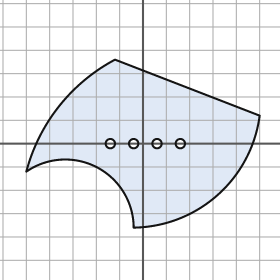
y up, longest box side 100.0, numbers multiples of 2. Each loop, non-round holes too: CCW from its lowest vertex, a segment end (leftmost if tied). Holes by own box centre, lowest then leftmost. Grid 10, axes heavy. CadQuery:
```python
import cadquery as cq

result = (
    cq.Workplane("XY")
    .moveTo(-4.0, -36.0)
    .threePointArc((32.0, -22.0), (50.0, 12.0))
    .lineTo(-12.0, 36.0)
    .threePointArc((-36.0, 16.0), (-50.0, -12.0))
    .threePointArc((-20.0, -10.0), (-4.0, -36.0))
    .close()
    .moveTo(-14.0, 0.0)
    .circle(2.0)
    .moveTo(-4.0, 0.0)
    .circle(2.0)
    .moveTo(6.0, 0.0)
    .circle(2.0)
    .moveTo(16.0, 0.0)
    .circle(2.0)
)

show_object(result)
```